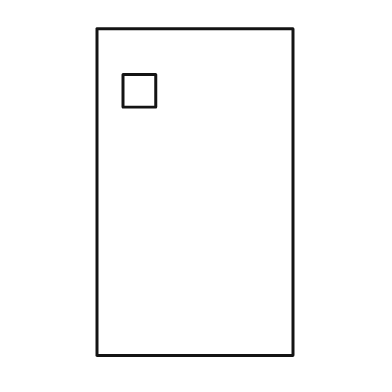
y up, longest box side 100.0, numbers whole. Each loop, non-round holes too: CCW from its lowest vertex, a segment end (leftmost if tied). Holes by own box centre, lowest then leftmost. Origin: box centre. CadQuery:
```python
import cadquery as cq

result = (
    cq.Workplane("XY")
    .moveTo(-30.0, -50.0)
    .lineTo(30.0, -50.0)
    .lineTo(30.0, 50.0)
    .lineTo(-30.0, 50.0)
    .close()
    .moveTo(-22.0, 26.0)
    .lineTo(-12.0, 26.0)
    .lineTo(-12.0, 36.0)
    .lineTo(-22.0, 36.0)
    .close()
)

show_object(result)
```